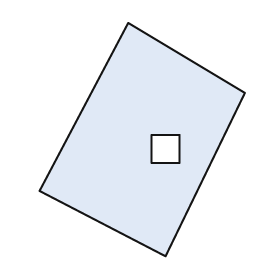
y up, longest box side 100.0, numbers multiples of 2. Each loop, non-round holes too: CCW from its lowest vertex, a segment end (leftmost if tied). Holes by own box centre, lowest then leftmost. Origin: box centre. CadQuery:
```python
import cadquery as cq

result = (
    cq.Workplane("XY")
    .moveTo(10.0, -50.0)
    .lineTo(44.0, 20.0)
    .lineTo(-6.0, 50.0)
    .lineTo(-44.0, -22.0)
    .close()
    .moveTo(4.0, -10.0)
    .lineTo(16.0, -10.0)
    .lineTo(16.0, 2.0)
    .lineTo(4.0, 2.0)
    .close()
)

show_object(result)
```